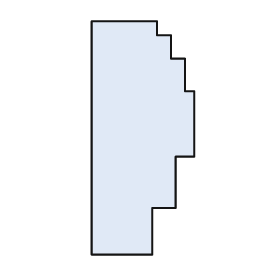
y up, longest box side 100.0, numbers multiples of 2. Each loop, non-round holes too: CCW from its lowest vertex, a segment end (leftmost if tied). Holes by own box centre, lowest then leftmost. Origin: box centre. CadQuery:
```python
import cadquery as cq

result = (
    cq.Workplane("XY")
    .moveTo(-22.0, -50.0)
    .lineTo(4.0, -50.0)
    .lineTo(4.0, -30.0)
    .lineTo(14.0, -30.0)
    .lineTo(14.0, -8.0)
    .lineTo(22.0, -8.0)
    .lineTo(22.0, 20.0)
    .lineTo(18.0, 20.0)
    .lineTo(18.0, 34.0)
    .lineTo(12.0, 34.0)
    .lineTo(12.0, 44.0)
    .lineTo(6.0, 44.0)
    .lineTo(6.0, 50.0)
    .lineTo(-22.0, 50.0)
    .close()
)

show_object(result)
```